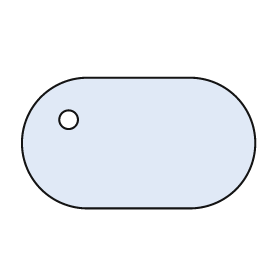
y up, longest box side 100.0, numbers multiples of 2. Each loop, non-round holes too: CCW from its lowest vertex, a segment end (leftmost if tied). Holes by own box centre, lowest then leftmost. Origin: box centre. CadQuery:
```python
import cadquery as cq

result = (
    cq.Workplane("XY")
    .moveTo(-22.0, -28.0)
    .lineTo(22.0, -28.0)
    .threePointArc((50.0, 0.0), (22.0, 28.0))
    .lineTo(-22.0, 28.0)
    .threePointArc((-50.0, 0.0), (-22.0, -28.0))
    .close()
    .moveTo(-30.0, 10.0)
    .circle(4.0)
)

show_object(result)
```